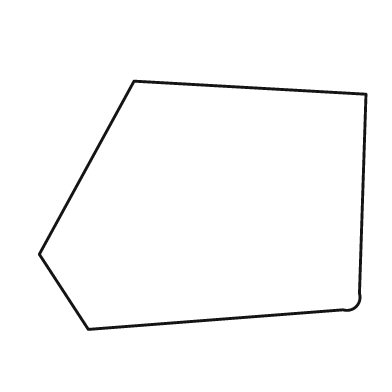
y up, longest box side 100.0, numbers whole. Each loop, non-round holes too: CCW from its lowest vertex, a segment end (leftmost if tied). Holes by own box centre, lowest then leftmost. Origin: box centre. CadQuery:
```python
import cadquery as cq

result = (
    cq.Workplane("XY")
    .moveTo(-35.0, -38.0)
    .lineTo(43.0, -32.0)
    .threePointArc((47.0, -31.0), (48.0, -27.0))
    .lineTo(50.0, 34.0)
    .lineTo(-21.0, 38.0)
    .lineTo(-50.0, -15.0)
    .close()
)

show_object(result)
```